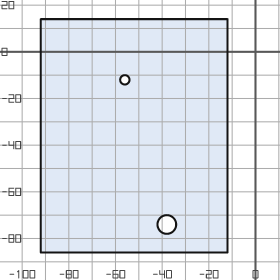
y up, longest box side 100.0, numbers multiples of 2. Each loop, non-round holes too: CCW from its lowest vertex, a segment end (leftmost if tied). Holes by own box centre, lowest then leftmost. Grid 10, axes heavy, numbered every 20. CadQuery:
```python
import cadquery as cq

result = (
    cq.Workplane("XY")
    .moveTo(-92.0, -86.0)
    .lineTo(-12.0, -86.0)
    .lineTo(-12.0, 14.0)
    .lineTo(-92.0, 14.0)
    .close()
    .moveTo(-38.0, -74.0)
    .circle(4.0)
    .moveTo(-56.0, -12.0)
    .circle(2.0)
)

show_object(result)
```